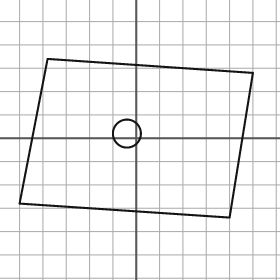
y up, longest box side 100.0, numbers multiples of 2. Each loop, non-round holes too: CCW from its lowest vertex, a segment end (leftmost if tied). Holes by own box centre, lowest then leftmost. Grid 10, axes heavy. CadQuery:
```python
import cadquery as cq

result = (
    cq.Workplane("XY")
    .moveTo(40.0, -34.0)
    .lineTo(50.0, 28.0)
    .lineTo(-38.0, 34.0)
    .lineTo(-50.0, -28.0)
    .close()
    .moveTo(-4.0, 2.0)
    .circle(6.0)
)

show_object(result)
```